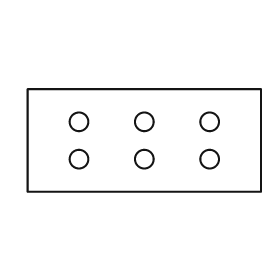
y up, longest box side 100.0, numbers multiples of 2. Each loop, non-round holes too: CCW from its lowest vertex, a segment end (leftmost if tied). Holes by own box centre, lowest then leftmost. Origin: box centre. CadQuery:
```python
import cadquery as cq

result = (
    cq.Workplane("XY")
    .moveTo(-50.0, -22.0)
    .lineTo(50.0, -22.0)
    .lineTo(50.0, 22.0)
    .lineTo(-50.0, 22.0)
    .close()
    .moveTo(-28.0, -8.0)
    .circle(4.0)
    .moveTo(0.0, -8.0)
    .circle(4.0)
    .moveTo(28.0, -8.0)
    .circle(4.0)
    .moveTo(-28.0, 8.0)
    .circle(4.0)
    .moveTo(0.0, 8.0)
    .circle(4.0)
    .moveTo(28.0, 8.0)
    .circle(4.0)
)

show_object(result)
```